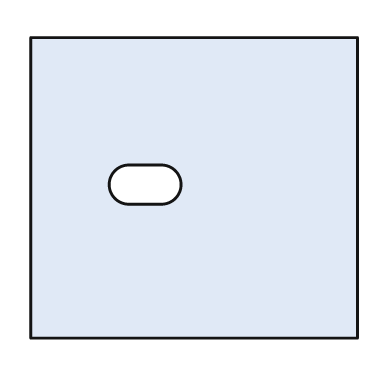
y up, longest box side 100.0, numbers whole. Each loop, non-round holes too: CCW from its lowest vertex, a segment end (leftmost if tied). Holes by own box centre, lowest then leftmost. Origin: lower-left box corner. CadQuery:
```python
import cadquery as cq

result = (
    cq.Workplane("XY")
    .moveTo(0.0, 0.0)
    .lineTo(100.0, 0.0)
    .lineTo(100.0, 92.0)
    .lineTo(0.0, 92.0)
    .close()
    .moveTo(30.0, 41.0)
    .lineTo(40.0, 41.0)
    .threePointArc((46.0, 47.0), (40.0, 53.0))
    .lineTo(30.0, 53.0)
    .threePointArc((24.0, 47.0), (30.0, 41.0))
    .close()
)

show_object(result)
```